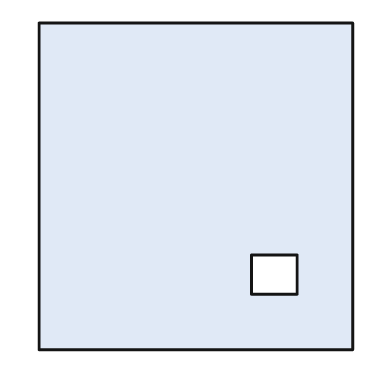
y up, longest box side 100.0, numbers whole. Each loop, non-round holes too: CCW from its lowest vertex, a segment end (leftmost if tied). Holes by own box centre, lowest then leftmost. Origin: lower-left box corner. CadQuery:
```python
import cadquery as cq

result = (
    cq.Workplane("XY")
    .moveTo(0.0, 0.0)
    .lineTo(96.0, 0.0)
    .lineTo(96.0, 100.0)
    .lineTo(0.0, 100.0)
    .close()
    .moveTo(65.0, 17.0)
    .lineTo(79.0, 17.0)
    .lineTo(79.0, 29.0)
    .lineTo(65.0, 29.0)
    .close()
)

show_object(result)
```